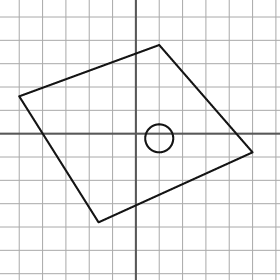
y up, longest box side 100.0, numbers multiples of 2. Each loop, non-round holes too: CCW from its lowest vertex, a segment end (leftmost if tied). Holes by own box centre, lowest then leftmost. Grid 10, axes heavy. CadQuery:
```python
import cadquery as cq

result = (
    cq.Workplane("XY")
    .moveTo(-16.0, -38.0)
    .lineTo(50.0, -8.0)
    .lineTo(10.0, 38.0)
    .lineTo(-50.0, 16.0)
    .close()
    .moveTo(10.0, -2.0)
    .circle(6.0)
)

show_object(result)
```